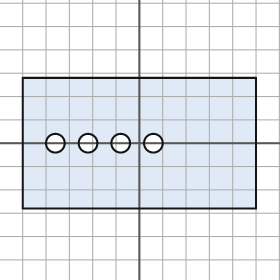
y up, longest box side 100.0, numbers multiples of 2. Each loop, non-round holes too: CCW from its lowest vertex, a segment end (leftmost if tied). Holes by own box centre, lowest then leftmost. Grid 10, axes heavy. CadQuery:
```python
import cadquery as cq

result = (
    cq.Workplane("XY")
    .moveTo(-50.0, -28.0)
    .lineTo(50.0, -28.0)
    .lineTo(50.0, 28.0)
    .lineTo(-50.0, 28.0)
    .close()
    .moveTo(-36.0, 0.0)
    .circle(4.0)
    .moveTo(-22.0, 0.0)
    .circle(4.0)
    .moveTo(-8.0, 0.0)
    .circle(4.0)
    .moveTo(6.0, 0.0)
    .circle(4.0)
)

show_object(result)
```